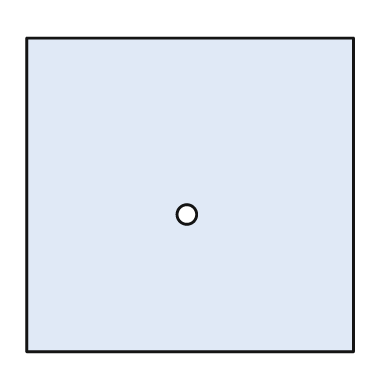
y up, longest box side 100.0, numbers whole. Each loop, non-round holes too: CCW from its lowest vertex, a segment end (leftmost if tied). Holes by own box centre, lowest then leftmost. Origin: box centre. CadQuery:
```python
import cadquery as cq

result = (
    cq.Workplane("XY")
    .moveTo(-50.0, -48.0)
    .lineTo(50.0, -48.0)
    .lineTo(50.0, 48.0)
    .lineTo(-50.0, 48.0)
    .close()
    .moveTo(-1.0, -6.0)
    .circle(3.0)
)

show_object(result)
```